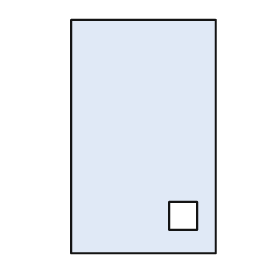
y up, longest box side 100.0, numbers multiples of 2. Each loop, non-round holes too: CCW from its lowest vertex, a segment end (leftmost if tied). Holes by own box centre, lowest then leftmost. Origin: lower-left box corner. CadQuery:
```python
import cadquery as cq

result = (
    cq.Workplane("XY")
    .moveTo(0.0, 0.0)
    .lineTo(62.0, 0.0)
    .lineTo(62.0, 100.0)
    .lineTo(0.0, 100.0)
    .close()
    .moveTo(42.0, 10.0)
    .lineTo(54.0, 10.0)
    .lineTo(54.0, 22.0)
    .lineTo(42.0, 22.0)
    .close()
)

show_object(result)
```